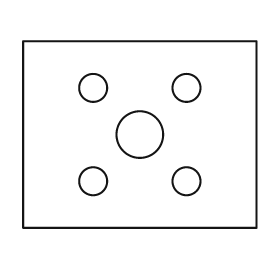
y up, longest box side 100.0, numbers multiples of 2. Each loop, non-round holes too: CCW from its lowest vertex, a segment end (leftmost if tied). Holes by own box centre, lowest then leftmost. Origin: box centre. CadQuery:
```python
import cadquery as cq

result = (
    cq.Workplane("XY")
    .moveTo(-50.0, -40.0)
    .lineTo(50.0, -40.0)
    .lineTo(50.0, 40.0)
    .lineTo(-50.0, 40.0)
    .close()
    .moveTo(-20.0, -20.0)
    .circle(6.0)
    .moveTo(20.0, -20.0)
    .circle(6.0)
    .moveTo(0.0, 0.0)
    .circle(10.0)
    .moveTo(-20.0, 20.0)
    .circle(6.0)
    .moveTo(20.0, 20.0)
    .circle(6.0)
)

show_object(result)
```